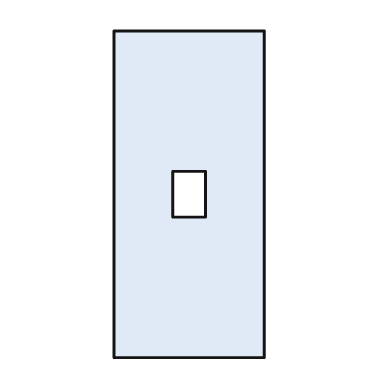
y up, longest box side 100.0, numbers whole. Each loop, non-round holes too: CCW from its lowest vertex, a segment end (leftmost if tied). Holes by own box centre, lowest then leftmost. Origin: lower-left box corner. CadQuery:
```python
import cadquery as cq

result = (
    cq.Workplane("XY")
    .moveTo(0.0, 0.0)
    .lineTo(46.0, 0.0)
    .lineTo(46.0, 100.0)
    .lineTo(0.0, 100.0)
    .close()
    .moveTo(18.0, 43.0)
    .lineTo(28.0, 43.0)
    .lineTo(28.0, 57.0)
    .lineTo(18.0, 57.0)
    .close()
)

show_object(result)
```